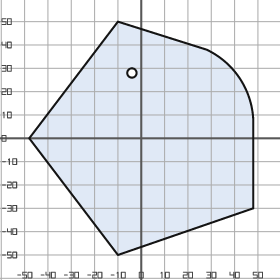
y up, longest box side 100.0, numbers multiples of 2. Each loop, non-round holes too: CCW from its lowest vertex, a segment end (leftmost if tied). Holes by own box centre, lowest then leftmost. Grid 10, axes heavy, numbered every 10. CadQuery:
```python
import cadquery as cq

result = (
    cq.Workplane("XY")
    .moveTo(-10.0, -50.0)
    .lineTo(48.0, -30.0)
    .lineTo(48.0, 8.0)
    .threePointArc((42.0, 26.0), (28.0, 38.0))
    .lineTo(-10.0, 50.0)
    .lineTo(-48.0, 0.0)
    .close()
    .moveTo(-4.0, 28.0)
    .circle(2.0)
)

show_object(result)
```